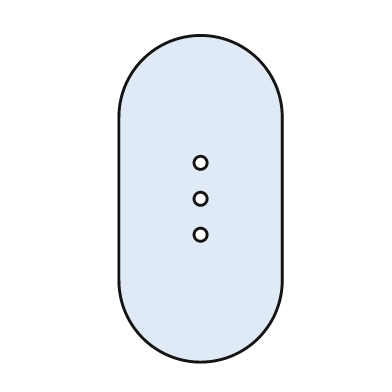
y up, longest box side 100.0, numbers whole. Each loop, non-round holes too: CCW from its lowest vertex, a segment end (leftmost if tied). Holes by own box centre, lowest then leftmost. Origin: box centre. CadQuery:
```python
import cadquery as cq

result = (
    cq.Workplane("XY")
    .moveTo(-25.0, -25.0)
    .threePointArc((0.0, -50.0), (25.0, -25.0))
    .lineTo(25.0, 25.0)
    .threePointArc((0.0, 50.0), (-25.0, 25.0))
    .close()
    .moveTo(0.0, -11.0)
    .circle(2.0)
    .moveTo(0.0, 0.0)
    .circle(2.0)
    .moveTo(0.0, 11.0)
    .circle(2.0)
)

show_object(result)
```